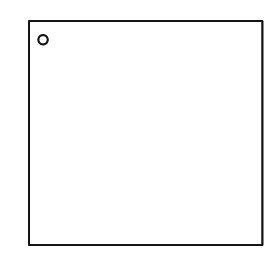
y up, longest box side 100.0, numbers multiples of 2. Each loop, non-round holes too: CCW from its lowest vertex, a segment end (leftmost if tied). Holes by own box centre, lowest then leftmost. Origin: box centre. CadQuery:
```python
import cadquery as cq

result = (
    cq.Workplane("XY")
    .moveTo(-50.0, -48.0)
    .lineTo(50.0, -48.0)
    .lineTo(50.0, 48.0)
    .lineTo(-50.0, 48.0)
    .close()
    .moveTo(-44.0, 40.0)
    .circle(2.0)
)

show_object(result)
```